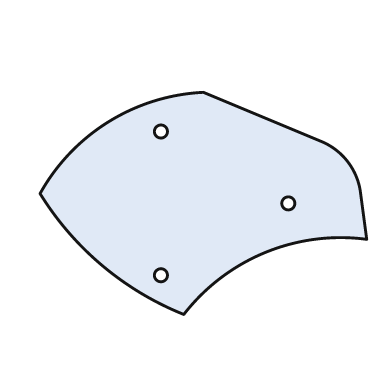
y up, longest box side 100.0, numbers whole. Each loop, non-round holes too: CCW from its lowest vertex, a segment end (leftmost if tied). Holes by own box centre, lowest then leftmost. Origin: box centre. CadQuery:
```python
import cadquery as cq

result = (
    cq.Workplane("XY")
    .moveTo(-6.0, -34.0)
    .threePointArc((19.0, -15.0), (50.0, -11.0))
    .lineTo(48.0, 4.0)
    .threePointArc((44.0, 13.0), (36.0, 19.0))
    .lineTo(0.0, 34.0)
    .threePointArc((-29.0, 25.0), (-50.0, 3.0))
    .threePointArc((-31.0, -19.0), (-6.0, -34.0))
    .close()
    .moveTo(-13.0, -22.0)
    .circle(2.0)
    .moveTo(26.0, 0.0)
    .circle(2.0)
    .moveTo(-13.0, 22.0)
    .circle(2.0)
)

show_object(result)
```